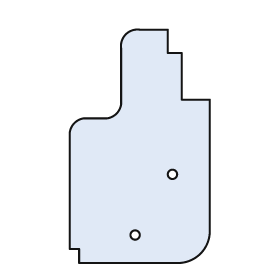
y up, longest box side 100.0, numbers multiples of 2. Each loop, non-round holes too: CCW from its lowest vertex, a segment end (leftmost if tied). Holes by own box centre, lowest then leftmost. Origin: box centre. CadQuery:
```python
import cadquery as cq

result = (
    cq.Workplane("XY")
    .moveTo(-26.0, -50.0)
    .lineTo(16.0, -50.0)
    .threePointArc((26.0, -46.0), (30.0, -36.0))
    .lineTo(30.0, 20.0)
    .lineTo(18.0, 20.0)
    .lineTo(18.0, 40.0)
    .lineTo(12.0, 40.0)
    .lineTo(12.0, 50.0)
    .lineTo(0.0, 50.0)
    .threePointArc((-6.0, 48.0), (-8.0, 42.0))
    .lineTo(-8.0, 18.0)
    .threePointArc((-10.0, 14.0), (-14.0, 12.0))
    .lineTo(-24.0, 12.0)
    .threePointArc((-28.0, 10.0), (-30.0, 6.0))
    .lineTo(-30.0, -44.0)
    .lineTo(-26.0, -44.0)
    .close()
    .moveTo(-2.0, -38.0)
    .circle(2.0)
    .moveTo(14.0, -12.0)
    .circle(2.0)
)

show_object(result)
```